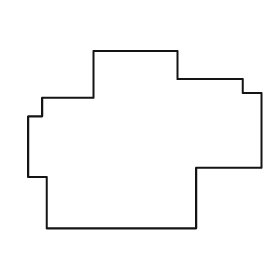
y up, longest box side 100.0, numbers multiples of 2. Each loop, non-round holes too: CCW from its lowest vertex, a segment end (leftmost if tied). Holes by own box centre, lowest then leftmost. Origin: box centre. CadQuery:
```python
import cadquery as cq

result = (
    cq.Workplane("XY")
    .moveTo(-42.0, -38.0)
    .lineTo(22.0, -38.0)
    .lineTo(22.0, -12.0)
    .lineTo(50.0, -12.0)
    .lineTo(50.0, 20.0)
    .lineTo(42.0, 20.0)
    .lineTo(42.0, 26.0)
    .lineTo(14.0, 26.0)
    .lineTo(14.0, 38.0)
    .lineTo(-22.0, 38.0)
    .lineTo(-22.0, 18.0)
    .lineTo(-44.0, 18.0)
    .lineTo(-44.0, 10.0)
    .lineTo(-50.0, 10.0)
    .lineTo(-50.0, -16.0)
    .lineTo(-42.0, -16.0)
    .close()
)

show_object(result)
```